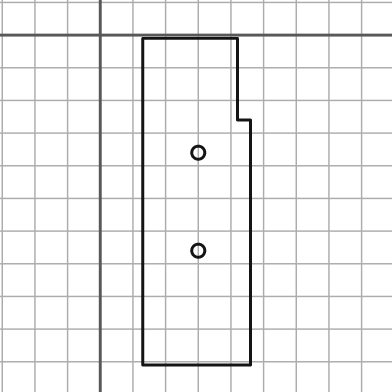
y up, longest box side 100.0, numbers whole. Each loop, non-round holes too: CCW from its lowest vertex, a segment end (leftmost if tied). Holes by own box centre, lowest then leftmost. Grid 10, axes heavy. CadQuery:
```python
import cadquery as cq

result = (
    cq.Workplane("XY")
    .moveTo(13.0, -101.0)
    .lineTo(46.0, -101.0)
    .lineTo(46.0, -26.0)
    .lineTo(42.0, -26.0)
    .lineTo(42.0, -1.0)
    .lineTo(13.0, -1.0)
    .close()
    .moveTo(30.0, -66.0)
    .circle(2.0)
    .moveTo(30.0, -36.0)
    .circle(2.0)
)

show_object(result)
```